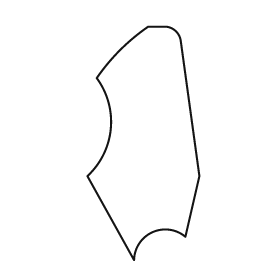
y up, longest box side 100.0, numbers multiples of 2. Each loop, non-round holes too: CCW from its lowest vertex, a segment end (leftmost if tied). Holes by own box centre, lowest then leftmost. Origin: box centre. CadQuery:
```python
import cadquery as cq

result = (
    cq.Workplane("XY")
    .moveTo(-4.0, -50.0)
    .threePointArc((4.0, -38.0), (18.0, -40.0))
    .lineTo(24.0, -14.0)
    .lineTo(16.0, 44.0)
    .threePointArc((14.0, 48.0), (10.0, 50.0))
    .lineTo(2.0, 50.0)
    .threePointArc((-10.0, 40.0), (-20.0, 28.0))
    .threePointArc((-14.0, 6.0), (-24.0, -14.0))
    .close()
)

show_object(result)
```